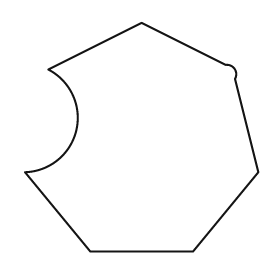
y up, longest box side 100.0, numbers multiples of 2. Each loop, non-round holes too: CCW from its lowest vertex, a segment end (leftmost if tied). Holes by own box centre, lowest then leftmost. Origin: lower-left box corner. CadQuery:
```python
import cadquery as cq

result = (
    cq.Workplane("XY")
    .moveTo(28.0, 0.0)
    .lineTo(72.0, 0.0)
    .lineTo(100.0, 34.0)
    .lineTo(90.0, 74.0)
    .threePointArc((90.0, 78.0), (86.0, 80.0))
    .lineTo(50.0, 98.0)
    .lineTo(10.0, 78.0)
    .threePointArc((22.0, 52.0), (0.0, 34.0))
    .close()
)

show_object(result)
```